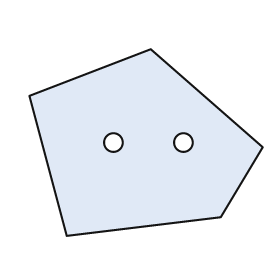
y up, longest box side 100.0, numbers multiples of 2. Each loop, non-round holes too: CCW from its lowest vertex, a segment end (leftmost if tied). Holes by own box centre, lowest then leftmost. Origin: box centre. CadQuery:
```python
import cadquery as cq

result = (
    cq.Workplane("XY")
    .moveTo(-34.0, -40.0)
    .lineTo(32.0, -32.0)
    .lineTo(50.0, -2.0)
    .lineTo(2.0, 40.0)
    .lineTo(-50.0, 20.0)
    .close()
    .moveTo(-14.0, 0.0)
    .circle(4.0)
    .moveTo(16.0, 0.0)
    .circle(4.0)
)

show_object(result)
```